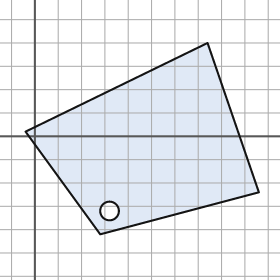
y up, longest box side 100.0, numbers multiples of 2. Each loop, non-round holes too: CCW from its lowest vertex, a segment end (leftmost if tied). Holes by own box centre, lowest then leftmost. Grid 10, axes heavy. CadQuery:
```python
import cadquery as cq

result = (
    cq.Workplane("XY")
    .moveTo(28.0, -42.0)
    .lineTo(96.0, -24.0)
    .lineTo(74.0, 40.0)
    .lineTo(-4.0, 2.0)
    .close()
    .moveTo(32.0, -32.0)
    .circle(4.0)
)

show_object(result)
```